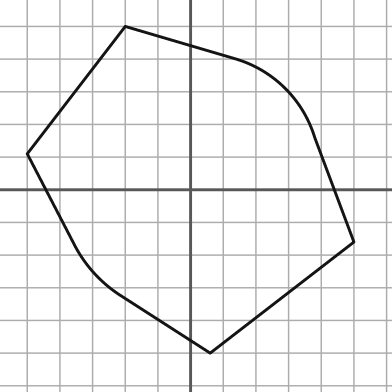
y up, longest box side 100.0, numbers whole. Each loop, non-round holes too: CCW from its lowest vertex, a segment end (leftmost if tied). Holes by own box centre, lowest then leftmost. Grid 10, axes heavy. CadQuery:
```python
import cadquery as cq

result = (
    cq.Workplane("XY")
    .moveTo(6.0, -50.0)
    .lineTo(50.0, -16.0)
    .lineTo(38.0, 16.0)
    .threePointArc((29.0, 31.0), (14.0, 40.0))
    .lineTo(-20.0, 50.0)
    .lineTo(-50.0, 11.0)
    .lineTo(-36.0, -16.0)
    .threePointArc((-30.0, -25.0), (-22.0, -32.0))
    .close()
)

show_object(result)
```